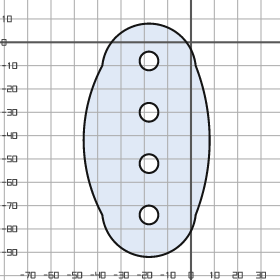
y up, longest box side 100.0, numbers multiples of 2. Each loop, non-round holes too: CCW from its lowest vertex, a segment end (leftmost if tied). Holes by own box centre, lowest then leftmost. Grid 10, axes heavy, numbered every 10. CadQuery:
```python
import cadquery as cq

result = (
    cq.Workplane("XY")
    .moveTo(-38.0, -74.0)
    .threePointArc((-18.0, -92.0), (2.0, -74.0))
    .threePointArc((8.0, -42.0), (2.0, -10.0))
    .threePointArc((-18.0, 8.0), (-38.0, -10.0))
    .threePointArc((-46.0, -42.0), (-38.0, -74.0))
    .close()
    .moveTo(-18.0, -74.0)
    .circle(4.0)
    .moveTo(-18.0, -52.0)
    .circle(4.0)
    .moveTo(-18.0, -30.0)
    .circle(4.0)
    .moveTo(-18.0, -8.0)
    .circle(4.0)
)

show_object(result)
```